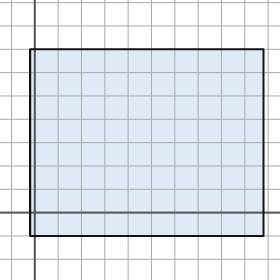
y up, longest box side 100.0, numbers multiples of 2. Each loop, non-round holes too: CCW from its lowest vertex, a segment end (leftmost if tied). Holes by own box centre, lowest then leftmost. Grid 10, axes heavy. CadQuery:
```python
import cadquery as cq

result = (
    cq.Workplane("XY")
    .moveTo(-2.0, -10.0)
    .lineTo(98.0, -10.0)
    .lineTo(98.0, 70.0)
    .lineTo(-2.0, 70.0)
    .close()
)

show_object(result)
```